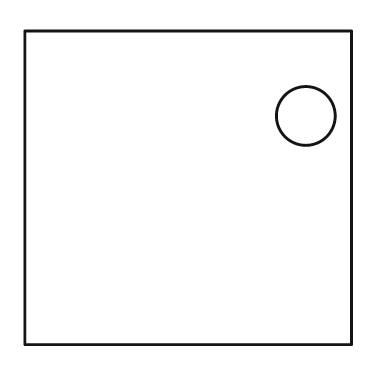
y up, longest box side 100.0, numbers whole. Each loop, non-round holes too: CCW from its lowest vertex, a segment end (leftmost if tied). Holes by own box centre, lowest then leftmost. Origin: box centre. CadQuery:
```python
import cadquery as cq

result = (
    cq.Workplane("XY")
    .moveTo(-50.0, -48.0)
    .lineTo(50.0, -48.0)
    .lineTo(50.0, 48.0)
    .lineTo(-50.0, 48.0)
    .close()
    .moveTo(36.0, 22.0)
    .circle(9.0)
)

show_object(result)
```